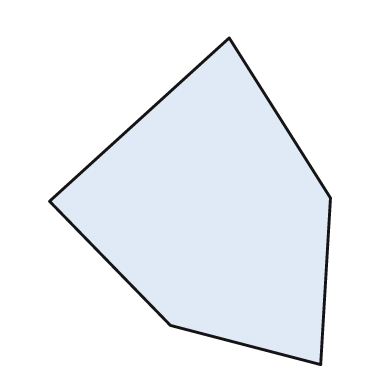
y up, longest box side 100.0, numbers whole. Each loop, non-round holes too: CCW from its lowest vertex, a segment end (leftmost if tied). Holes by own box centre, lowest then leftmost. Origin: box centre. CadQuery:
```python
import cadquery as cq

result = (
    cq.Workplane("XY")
    .moveTo(40.0, -50.0)
    .lineTo(43.0, 1.0)
    .lineTo(12.0, 50.0)
    .lineTo(-43.0, 0.0)
    .lineTo(-6.0, -38.0)
    .close()
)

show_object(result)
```